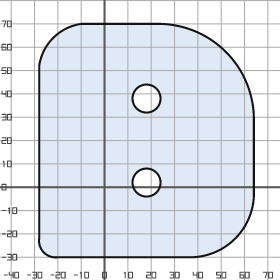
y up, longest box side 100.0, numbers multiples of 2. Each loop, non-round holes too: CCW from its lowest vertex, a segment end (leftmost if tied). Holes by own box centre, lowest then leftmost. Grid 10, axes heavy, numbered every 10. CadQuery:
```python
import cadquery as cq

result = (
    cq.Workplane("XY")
    .moveTo(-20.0, -30.0)
    .lineTo(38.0, -30.0)
    .threePointArc((56.0, -22.0), (64.0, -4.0))
    .lineTo(64.0, 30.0)
    .threePointArc((52.0, 58.0), (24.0, 70.0))
    .lineTo(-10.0, 70.0)
    .threePointArc((-22.0, 64.0), (-28.0, 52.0))
    .lineTo(-28.0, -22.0)
    .threePointArc((-26.0, -28.0), (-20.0, -30.0))
    .close()
    .moveTo(18.0, 2.0)
    .circle(6.0)
    .moveTo(18.0, 38.0)
    .circle(6.0)
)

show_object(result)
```